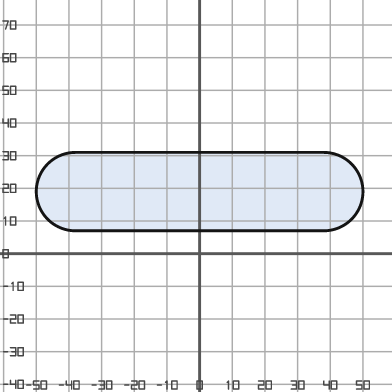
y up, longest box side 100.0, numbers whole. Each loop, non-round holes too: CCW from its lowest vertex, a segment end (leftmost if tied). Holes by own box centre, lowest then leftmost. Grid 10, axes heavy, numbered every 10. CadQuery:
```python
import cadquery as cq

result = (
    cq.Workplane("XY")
    .moveTo(-38.0, 7.0)
    .lineTo(38.0, 7.0)
    .threePointArc((50.0, 19.0), (38.0, 31.0))
    .lineTo(-38.0, 31.0)
    .threePointArc((-50.0, 19.0), (-38.0, 7.0))
    .close()
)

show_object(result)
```